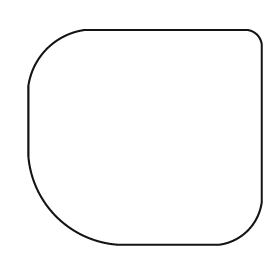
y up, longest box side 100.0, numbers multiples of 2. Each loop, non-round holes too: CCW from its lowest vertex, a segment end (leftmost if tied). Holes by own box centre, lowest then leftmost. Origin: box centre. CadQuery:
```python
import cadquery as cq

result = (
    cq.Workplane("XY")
    .moveTo(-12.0, -46.0)
    .lineTo(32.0, -46.0)
    .threePointArc((44.0, -40.0), (50.0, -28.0))
    .lineTo(50.0, 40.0)
    .threePointArc((48.0, 44.0), (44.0, 46.0))
    .lineTo(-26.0, 46.0)
    .threePointArc((-42.0, 38.0), (-50.0, 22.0))
    .lineTo(-50.0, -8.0)
    .threePointArc((-38.0, -34.0), (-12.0, -46.0))
    .close()
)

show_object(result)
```